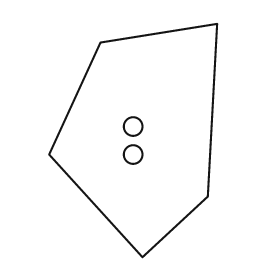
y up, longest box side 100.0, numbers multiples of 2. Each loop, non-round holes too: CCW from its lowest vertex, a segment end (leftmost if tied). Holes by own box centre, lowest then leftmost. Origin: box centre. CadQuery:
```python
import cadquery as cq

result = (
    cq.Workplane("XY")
    .moveTo(4.0, -50.0)
    .lineTo(32.0, -24.0)
    .lineTo(36.0, 50.0)
    .lineTo(-14.0, 42.0)
    .lineTo(-36.0, -6.0)
    .close()
    .moveTo(0.0, -6.0)
    .circle(4.0)
    .moveTo(0.0, 6.0)
    .circle(4.0)
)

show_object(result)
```